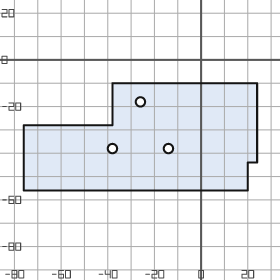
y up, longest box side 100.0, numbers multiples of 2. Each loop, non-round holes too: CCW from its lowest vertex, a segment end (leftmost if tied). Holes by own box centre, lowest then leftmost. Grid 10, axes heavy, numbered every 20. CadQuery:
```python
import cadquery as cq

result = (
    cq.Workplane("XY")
    .moveTo(-76.0, -56.0)
    .lineTo(20.0, -56.0)
    .lineTo(20.0, -44.0)
    .lineTo(24.0, -44.0)
    .lineTo(24.0, -10.0)
    .lineTo(-38.0, -10.0)
    .lineTo(-38.0, -28.0)
    .lineTo(-76.0, -28.0)
    .close()
    .moveTo(-38.0, -38.0)
    .circle(2.0)
    .moveTo(-14.0, -38.0)
    .circle(2.0)
    .moveTo(-26.0, -18.0)
    .circle(2.0)
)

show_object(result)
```